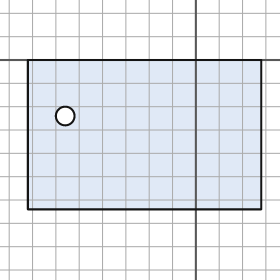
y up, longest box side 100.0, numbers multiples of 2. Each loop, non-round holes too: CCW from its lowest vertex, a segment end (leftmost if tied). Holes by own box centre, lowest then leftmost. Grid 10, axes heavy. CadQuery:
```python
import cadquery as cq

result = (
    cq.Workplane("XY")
    .moveTo(-72.0, -64.0)
    .lineTo(28.0, -64.0)
    .lineTo(28.0, 0.0)
    .lineTo(-72.0, 0.0)
    .close()
    .moveTo(-56.0, -24.0)
    .circle(4.0)
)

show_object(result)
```